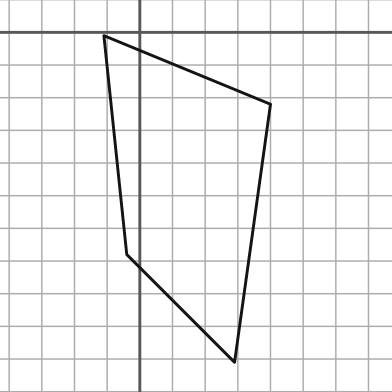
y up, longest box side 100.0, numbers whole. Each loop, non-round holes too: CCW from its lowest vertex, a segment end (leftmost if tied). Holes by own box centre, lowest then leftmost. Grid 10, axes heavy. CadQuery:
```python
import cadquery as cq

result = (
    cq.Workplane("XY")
    .moveTo(29.0, -101.0)
    .lineTo(40.0, -22.0)
    .lineTo(-11.0, -1.0)
    .lineTo(-4.0, -68.0)
    .close()
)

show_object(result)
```